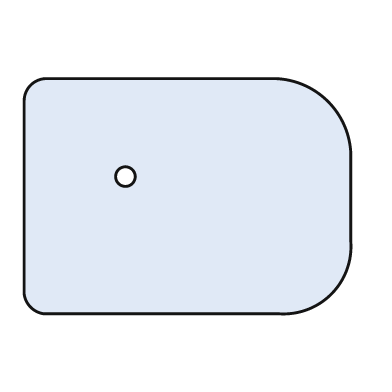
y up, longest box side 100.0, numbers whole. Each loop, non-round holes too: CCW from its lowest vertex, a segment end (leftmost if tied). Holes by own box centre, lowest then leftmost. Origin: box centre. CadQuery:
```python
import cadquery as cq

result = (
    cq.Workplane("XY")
    .moveTo(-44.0, -36.0)
    .lineTo(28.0, -36.0)
    .threePointArc((44.0, -30.0), (50.0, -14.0))
    .lineTo(50.0, 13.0)
    .threePointArc((43.0, 29.0), (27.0, 36.0))
    .lineTo(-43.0, 36.0)
    .threePointArc((-48.0, 34.0), (-50.0, 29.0))
    .lineTo(-50.0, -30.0)
    .threePointArc((-48.0, -34.0), (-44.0, -36.0))
    .close()
    .moveTo(-19.0, 6.0)
    .circle(3.0)
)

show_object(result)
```